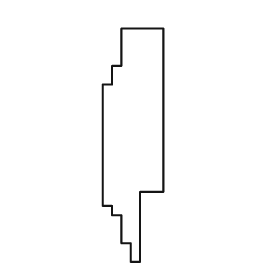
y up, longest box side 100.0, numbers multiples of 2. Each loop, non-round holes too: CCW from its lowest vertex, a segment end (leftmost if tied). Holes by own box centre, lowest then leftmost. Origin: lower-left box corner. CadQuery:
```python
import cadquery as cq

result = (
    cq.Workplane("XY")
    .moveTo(12.0, 0.0)
    .lineTo(16.0, 0.0)
    .lineTo(16.0, 30.0)
    .lineTo(26.0, 30.0)
    .lineTo(26.0, 100.0)
    .lineTo(8.0, 100.0)
    .lineTo(8.0, 84.0)
    .lineTo(4.0, 84.0)
    .lineTo(4.0, 76.0)
    .lineTo(0.0, 76.0)
    .lineTo(0.0, 24.0)
    .lineTo(4.0, 24.0)
    .lineTo(4.0, 20.0)
    .lineTo(8.0, 20.0)
    .lineTo(8.0, 8.0)
    .lineTo(12.0, 8.0)
    .close()
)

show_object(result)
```